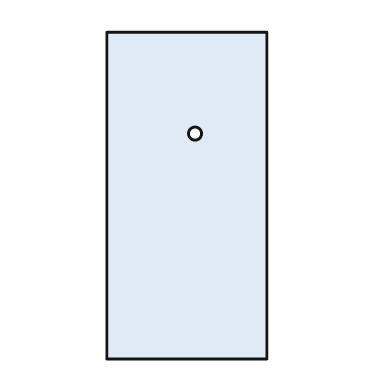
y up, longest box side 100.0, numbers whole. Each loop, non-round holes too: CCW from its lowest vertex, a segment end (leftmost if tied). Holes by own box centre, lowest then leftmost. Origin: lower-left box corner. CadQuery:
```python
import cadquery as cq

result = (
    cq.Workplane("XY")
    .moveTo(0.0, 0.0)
    .lineTo(49.0, 0.0)
    .lineTo(49.0, 100.0)
    .lineTo(0.0, 100.0)
    .close()
    .moveTo(27.0, 69.0)
    .circle(2.0)
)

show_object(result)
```